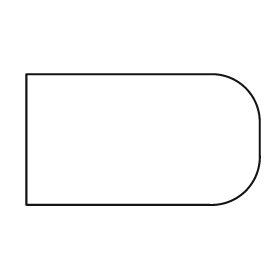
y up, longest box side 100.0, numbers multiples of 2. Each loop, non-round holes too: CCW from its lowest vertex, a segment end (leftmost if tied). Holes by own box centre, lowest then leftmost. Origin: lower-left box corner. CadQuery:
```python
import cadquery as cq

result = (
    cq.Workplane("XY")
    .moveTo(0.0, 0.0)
    .lineTo(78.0, 0.0)
    .threePointArc((94.0, 6.0), (100.0, 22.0))
    .lineTo(100.0, 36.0)
    .threePointArc((94.0, 50.0), (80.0, 56.0))
    .lineTo(0.0, 56.0)
    .close()
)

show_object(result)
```